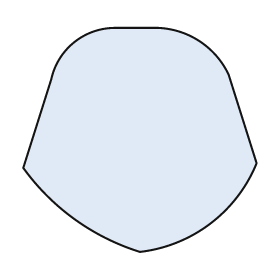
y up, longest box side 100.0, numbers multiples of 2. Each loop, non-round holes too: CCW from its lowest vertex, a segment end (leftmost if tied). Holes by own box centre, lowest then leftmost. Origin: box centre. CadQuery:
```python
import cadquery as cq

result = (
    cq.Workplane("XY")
    .moveTo(0.0, -48.0)
    .threePointArc((30.0, -36.0), (50.0, -10.0))
    .lineTo(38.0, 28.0)
    .threePointArc((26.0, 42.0), (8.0, 48.0))
    .lineTo(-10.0, 48.0)
    .threePointArc((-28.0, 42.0), (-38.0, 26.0))
    .lineTo(-50.0, -12.0)
    .threePointArc((-28.0, -34.0), (0.0, -48.0))
    .close()
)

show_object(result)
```